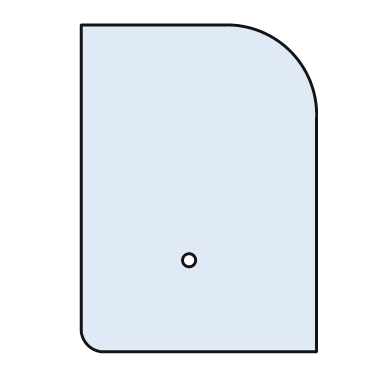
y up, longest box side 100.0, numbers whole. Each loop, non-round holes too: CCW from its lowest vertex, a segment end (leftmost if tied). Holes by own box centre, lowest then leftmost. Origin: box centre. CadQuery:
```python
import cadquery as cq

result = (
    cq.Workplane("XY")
    .moveTo(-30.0, -50.0)
    .lineTo(36.0, -50.0)
    .lineTo(36.0, 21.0)
    .threePointArc((28.0, 42.0), (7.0, 50.0))
    .lineTo(-36.0, 50.0)
    .lineTo(-36.0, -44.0)
    .threePointArc((-34.0, -48.0), (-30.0, -50.0))
    .close()
    .moveTo(-3.0, -22.0)
    .circle(2.0)
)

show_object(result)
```